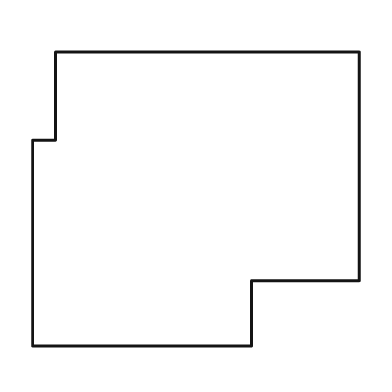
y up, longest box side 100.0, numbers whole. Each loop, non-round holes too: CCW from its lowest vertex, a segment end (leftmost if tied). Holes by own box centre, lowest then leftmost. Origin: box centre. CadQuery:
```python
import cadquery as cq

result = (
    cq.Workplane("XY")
    .moveTo(-50.0, -45.0)
    .lineTo(17.0, -45.0)
    .lineTo(17.0, -25.0)
    .lineTo(50.0, -25.0)
    .lineTo(50.0, 45.0)
    .lineTo(-43.0, 45.0)
    .lineTo(-43.0, 18.0)
    .lineTo(-50.0, 18.0)
    .close()
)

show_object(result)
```